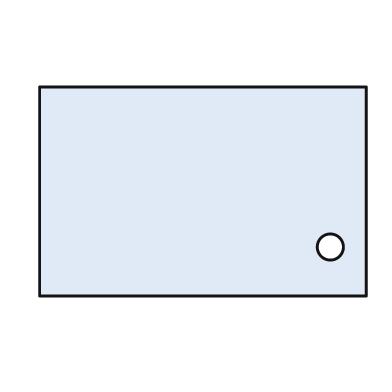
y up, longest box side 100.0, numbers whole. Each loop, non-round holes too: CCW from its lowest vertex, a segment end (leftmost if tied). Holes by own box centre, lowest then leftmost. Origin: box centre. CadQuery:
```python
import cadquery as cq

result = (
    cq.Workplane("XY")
    .moveTo(-50.0, -32.0)
    .lineTo(50.0, -32.0)
    .lineTo(50.0, 32.0)
    .lineTo(-50.0, 32.0)
    .close()
    .moveTo(39.0, -17.0)
    .circle(4.0)
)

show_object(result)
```